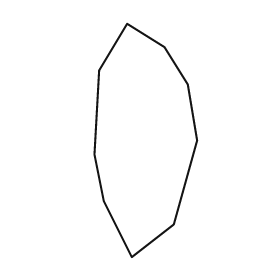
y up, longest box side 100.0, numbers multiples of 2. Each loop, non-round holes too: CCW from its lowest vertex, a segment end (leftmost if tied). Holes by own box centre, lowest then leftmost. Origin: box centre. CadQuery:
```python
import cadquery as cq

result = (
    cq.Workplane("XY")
    .moveTo(-6.0, -50.0)
    .lineTo(12.0, -36.0)
    .lineTo(22.0, 0.0)
    .lineTo(18.0, 24.0)
    .lineTo(8.0, 40.0)
    .lineTo(-8.0, 50.0)
    .lineTo(-20.0, 30.0)
    .lineTo(-22.0, -6.0)
    .lineTo(-18.0, -26.0)
    .close()
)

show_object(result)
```